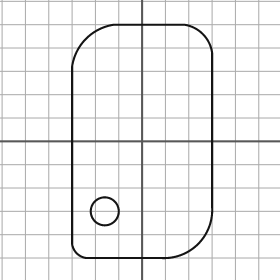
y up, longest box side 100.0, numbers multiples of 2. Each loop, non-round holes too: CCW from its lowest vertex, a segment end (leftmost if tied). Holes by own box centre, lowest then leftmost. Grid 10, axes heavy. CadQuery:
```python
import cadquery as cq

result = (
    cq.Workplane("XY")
    .moveTo(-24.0, -50.0)
    .lineTo(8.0, -50.0)
    .threePointArc((24.0, -44.0), (30.0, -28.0))
    .lineTo(30.0, 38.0)
    .threePointArc((26.0, 46.0), (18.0, 50.0))
    .lineTo(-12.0, 50.0)
    .threePointArc((-24.0, 44.0), (-30.0, 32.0))
    .lineTo(-30.0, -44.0)
    .threePointArc((-28.0, -48.0), (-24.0, -50.0))
    .close()
    .moveTo(-16.0, -30.0)
    .circle(6.0)
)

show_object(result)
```